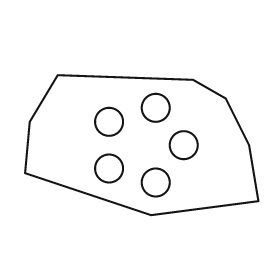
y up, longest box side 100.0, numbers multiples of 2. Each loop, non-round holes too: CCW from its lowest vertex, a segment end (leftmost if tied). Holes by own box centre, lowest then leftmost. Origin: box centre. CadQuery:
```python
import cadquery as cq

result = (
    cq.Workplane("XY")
    .moveTo(4.0, -30.0)
    .lineTo(50.0, -24.0)
    .lineTo(46.0, 0.0)
    .lineTo(36.0, 20.0)
    .lineTo(22.0, 28.0)
    .lineTo(-36.0, 30.0)
    .lineTo(-48.0, 10.0)
    .lineTo(-50.0, -12.0)
    .close()
    .moveTo(6.0, -16.0)
    .circle(6.0)
    .moveTo(-14.0, -10.0)
    .circle(6.0)
    .moveTo(18.0, 0.0)
    .circle(6.0)
    .moveTo(-14.0, 10.0)
    .circle(6.0)
    .moveTo(6.0, 16.0)
    .circle(6.0)
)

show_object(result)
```